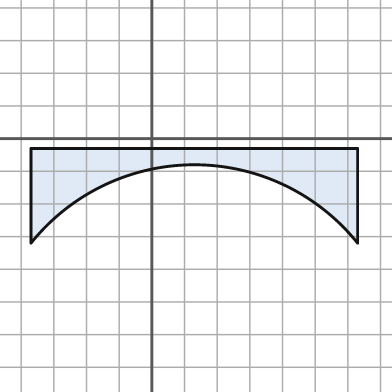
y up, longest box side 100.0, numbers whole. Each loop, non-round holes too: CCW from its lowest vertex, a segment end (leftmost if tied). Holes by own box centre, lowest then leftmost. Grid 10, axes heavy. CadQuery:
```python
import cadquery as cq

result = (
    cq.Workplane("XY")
    .moveTo(-37.0, -32.0)
    .threePointArc((13.0, -8.0), (63.0, -32.0))
    .lineTo(63.0, -3.0)
    .lineTo(-37.0, -3.0)
    .close()
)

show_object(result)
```